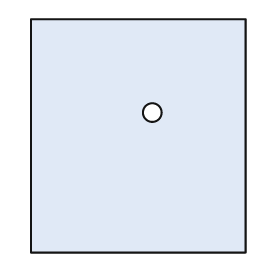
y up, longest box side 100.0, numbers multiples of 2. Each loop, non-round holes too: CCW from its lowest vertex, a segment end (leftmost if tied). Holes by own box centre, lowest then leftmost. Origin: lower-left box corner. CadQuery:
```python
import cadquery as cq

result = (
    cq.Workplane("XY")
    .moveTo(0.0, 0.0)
    .lineTo(92.0, 0.0)
    .lineTo(92.0, 100.0)
    .lineTo(0.0, 100.0)
    .close()
    .moveTo(52.0, 60.0)
    .circle(4.0)
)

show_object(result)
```